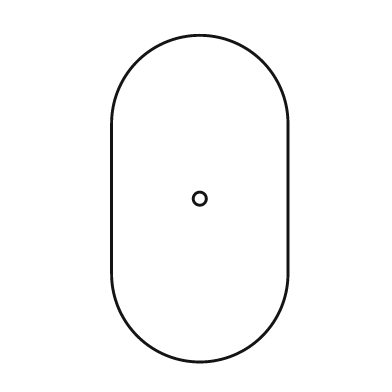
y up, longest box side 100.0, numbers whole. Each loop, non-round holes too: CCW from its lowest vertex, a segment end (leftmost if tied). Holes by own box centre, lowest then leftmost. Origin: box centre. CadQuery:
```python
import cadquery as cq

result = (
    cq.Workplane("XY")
    .moveTo(-27.0, -23.0)
    .threePointArc((0.0, -50.0), (27.0, -23.0))
    .lineTo(27.0, 23.0)
    .threePointArc((0.0, 50.0), (-27.0, 23.0))
    .close()
    .moveTo(0.0, 0.0)
    .circle(2.0)
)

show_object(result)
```